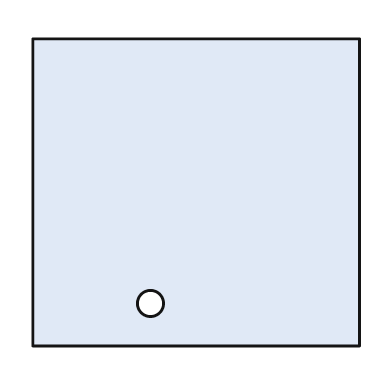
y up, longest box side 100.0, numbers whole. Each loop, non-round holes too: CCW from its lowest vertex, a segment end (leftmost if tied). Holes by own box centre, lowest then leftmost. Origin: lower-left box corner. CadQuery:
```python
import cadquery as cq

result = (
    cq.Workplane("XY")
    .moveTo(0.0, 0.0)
    .lineTo(100.0, 0.0)
    .lineTo(100.0, 94.0)
    .lineTo(0.0, 94.0)
    .close()
    .moveTo(36.0, 13.0)
    .circle(4.0)
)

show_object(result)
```